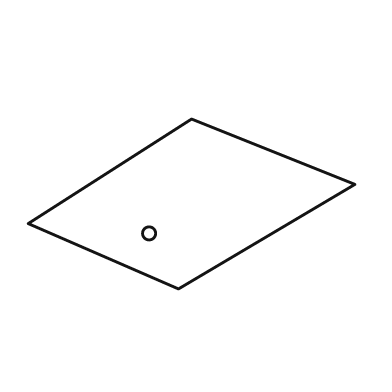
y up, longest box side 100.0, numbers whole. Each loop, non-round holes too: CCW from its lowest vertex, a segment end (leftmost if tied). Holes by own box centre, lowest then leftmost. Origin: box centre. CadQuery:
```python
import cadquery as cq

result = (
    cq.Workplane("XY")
    .moveTo(-4.0, -26.0)
    .lineTo(50.0, 6.0)
    .lineTo(0.0, 26.0)
    .lineTo(-50.0, -6.0)
    .close()
    .moveTo(-13.0, -9.0)
    .circle(2.0)
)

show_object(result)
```